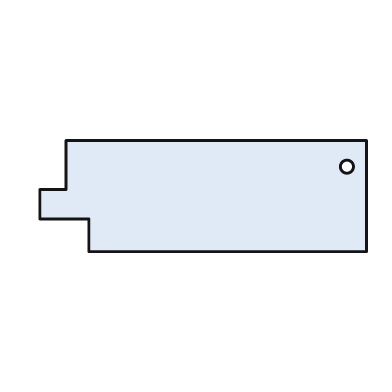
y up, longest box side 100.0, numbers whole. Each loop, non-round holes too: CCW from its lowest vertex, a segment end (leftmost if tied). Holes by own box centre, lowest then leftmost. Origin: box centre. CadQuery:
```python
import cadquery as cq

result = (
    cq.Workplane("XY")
    .moveTo(-35.0, -17.0)
    .lineTo(50.0, -17.0)
    .lineTo(50.0, 17.0)
    .lineTo(-42.0, 17.0)
    .lineTo(-42.0, 2.0)
    .lineTo(-50.0, 2.0)
    .lineTo(-50.0, -7.0)
    .lineTo(-35.0, -7.0)
    .close()
    .moveTo(44.0, 9.0)
    .circle(2.0)
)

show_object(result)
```